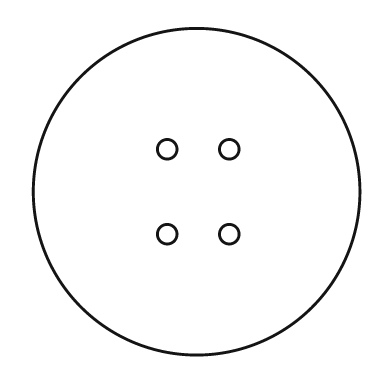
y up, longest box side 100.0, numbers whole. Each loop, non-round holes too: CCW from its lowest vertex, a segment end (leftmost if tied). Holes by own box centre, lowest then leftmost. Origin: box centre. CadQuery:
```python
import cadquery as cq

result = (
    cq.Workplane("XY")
    .moveTo(0.0, 0.0)
    .circle(50.0)
    .moveTo(-9.0, -13.0)
    .circle(3.0)
    .moveTo(10.0, -13.0)
    .circle(3.0)
    .moveTo(-9.0, 13.0)
    .circle(3.0)
    .moveTo(10.0, 13.0)
    .circle(3.0)
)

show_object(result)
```